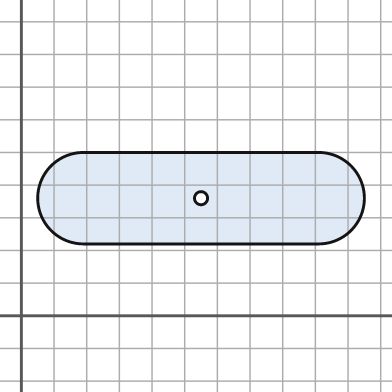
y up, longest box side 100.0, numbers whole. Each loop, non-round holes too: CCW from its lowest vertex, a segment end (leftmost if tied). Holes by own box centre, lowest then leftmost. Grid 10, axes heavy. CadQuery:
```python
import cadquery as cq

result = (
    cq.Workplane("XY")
    .moveTo(19.0, 22.0)
    .lineTo(91.0, 22.0)
    .threePointArc((105.0, 36.0), (91.0, 50.0))
    .lineTo(19.0, 50.0)
    .threePointArc((5.0, 36.0), (19.0, 22.0))
    .close()
    .moveTo(55.0, 36.0)
    .circle(2.0)
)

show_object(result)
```